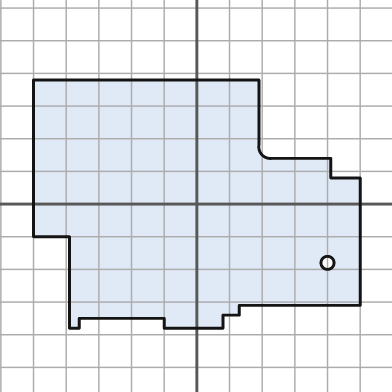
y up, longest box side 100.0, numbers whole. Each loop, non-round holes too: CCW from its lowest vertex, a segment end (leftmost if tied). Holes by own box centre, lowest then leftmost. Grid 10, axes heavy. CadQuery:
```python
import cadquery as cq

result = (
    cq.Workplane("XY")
    .moveTo(-39.0, -38.0)
    .lineTo(-36.0, -38.0)
    .lineTo(-36.0, -35.0)
    .lineTo(-10.0, -35.0)
    .lineTo(-10.0, -38.0)
    .lineTo(8.0, -38.0)
    .lineTo(8.0, -34.0)
    .lineTo(13.0, -34.0)
    .lineTo(13.0, -31.0)
    .lineTo(50.0, -31.0)
    .lineTo(50.0, 8.0)
    .lineTo(41.0, 8.0)
    .lineTo(41.0, 14.0)
    .lineTo(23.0, 14.0)
    .threePointArc((20.0, 15.0), (19.0, 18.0))
    .lineTo(19.0, 38.0)
    .lineTo(-50.0, 38.0)
    .lineTo(-50.0, -10.0)
    .lineTo(-39.0, -10.0)
    .close()
    .moveTo(40.0, -18.0)
    .circle(2.0)
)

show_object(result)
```